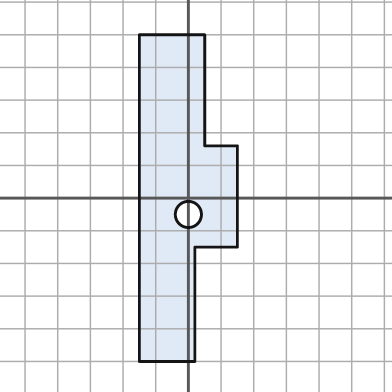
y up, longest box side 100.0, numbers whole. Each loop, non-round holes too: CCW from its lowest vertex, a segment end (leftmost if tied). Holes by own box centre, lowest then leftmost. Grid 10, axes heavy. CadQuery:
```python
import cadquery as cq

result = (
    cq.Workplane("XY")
    .moveTo(-15.0, -50.0)
    .lineTo(2.0, -50.0)
    .lineTo(2.0, -15.0)
    .lineTo(15.0, -15.0)
    .lineTo(15.0, 16.0)
    .lineTo(5.0, 16.0)
    .lineTo(5.0, 50.0)
    .lineTo(-15.0, 50.0)
    .close()
    .moveTo(0.0, -5.0)
    .circle(4.0)
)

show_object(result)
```